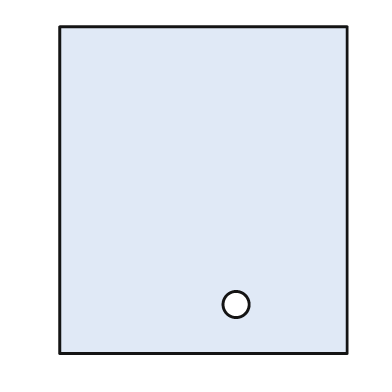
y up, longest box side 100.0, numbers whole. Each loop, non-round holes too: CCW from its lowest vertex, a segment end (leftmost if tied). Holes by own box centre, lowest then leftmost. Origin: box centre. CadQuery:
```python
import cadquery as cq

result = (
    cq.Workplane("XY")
    .moveTo(-44.0, -50.0)
    .lineTo(44.0, -50.0)
    .lineTo(44.0, 50.0)
    .lineTo(-44.0, 50.0)
    .close()
    .moveTo(10.0, -35.0)
    .circle(4.0)
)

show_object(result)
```